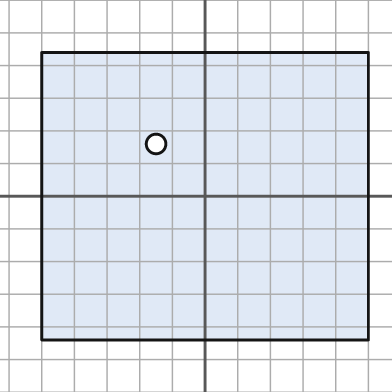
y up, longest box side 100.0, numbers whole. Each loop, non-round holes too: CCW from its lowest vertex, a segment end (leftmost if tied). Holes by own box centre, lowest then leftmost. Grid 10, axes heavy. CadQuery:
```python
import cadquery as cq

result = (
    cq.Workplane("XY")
    .moveTo(-50.0, -44.0)
    .lineTo(50.0, -44.0)
    .lineTo(50.0, 44.0)
    .lineTo(-50.0, 44.0)
    .close()
    .moveTo(-15.0, 16.0)
    .circle(3.0)
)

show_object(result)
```